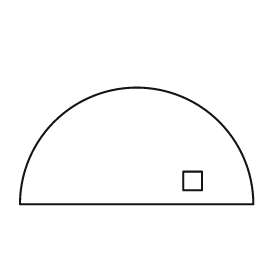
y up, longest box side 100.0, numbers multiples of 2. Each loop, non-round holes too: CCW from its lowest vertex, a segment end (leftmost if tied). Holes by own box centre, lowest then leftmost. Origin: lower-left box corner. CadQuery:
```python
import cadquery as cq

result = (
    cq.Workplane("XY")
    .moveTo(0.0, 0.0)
    .lineTo(100.0, 0.0)
    .threePointArc((50.0, 50.0), (0.0, 0.0))
    .close()
    .moveTo(70.0, 6.0)
    .lineTo(78.0, 6.0)
    .lineTo(78.0, 14.0)
    .lineTo(70.0, 14.0)
    .close()
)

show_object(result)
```